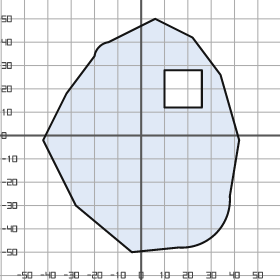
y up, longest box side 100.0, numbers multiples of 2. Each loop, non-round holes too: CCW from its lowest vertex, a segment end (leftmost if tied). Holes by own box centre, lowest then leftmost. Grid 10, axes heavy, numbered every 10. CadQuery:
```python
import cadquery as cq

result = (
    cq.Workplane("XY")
    .moveTo(-4.0, -50.0)
    .lineTo(16.0, -48.0)
    .threePointArc((32.0, -42.0), (38.0, -26.0))
    .lineTo(42.0, -2.0)
    .lineTo(34.0, 26.0)
    .lineTo(22.0, 42.0)
    .lineTo(6.0, 50.0)
    .lineTo(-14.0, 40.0)
    .threePointArc((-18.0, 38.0), (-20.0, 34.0))
    .lineTo(-32.0, 18.0)
    .lineTo(-42.0, -2.0)
    .lineTo(-28.0, -30.0)
    .close()
    .moveTo(10.0, 12.0)
    .lineTo(26.0, 12.0)
    .lineTo(26.0, 28.0)
    .lineTo(10.0, 28.0)
    .close()
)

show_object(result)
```